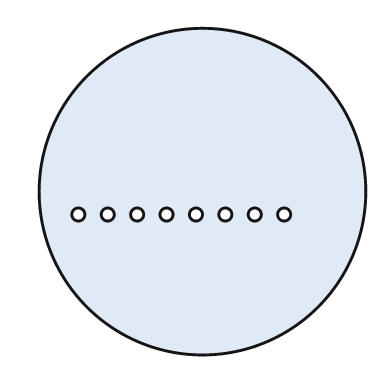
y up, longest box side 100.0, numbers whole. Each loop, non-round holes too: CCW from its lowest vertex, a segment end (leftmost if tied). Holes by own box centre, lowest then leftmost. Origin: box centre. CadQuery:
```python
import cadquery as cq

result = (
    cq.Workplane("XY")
    .moveTo(0.0, 0.0)
    .circle(50.0)
    .moveTo(-38.0, -7.0)
    .circle(2.0)
    .moveTo(-29.0, -7.0)
    .circle(2.0)
    .moveTo(-20.0, -7.0)
    .circle(2.0)
    .moveTo(-11.0, -7.0)
    .circle(2.0)
    .moveTo(-2.0, -7.0)
    .circle(2.0)
    .moveTo(7.0, -7.0)
    .circle(2.0)
    .moveTo(16.0, -7.0)
    .circle(2.0)
    .moveTo(25.0, -7.0)
    .circle(2.0)
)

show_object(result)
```